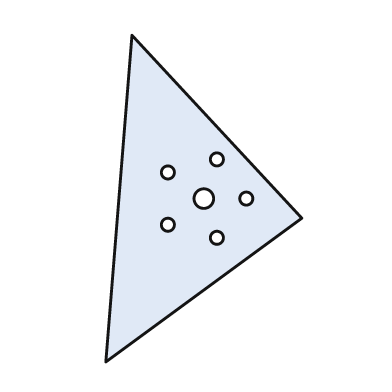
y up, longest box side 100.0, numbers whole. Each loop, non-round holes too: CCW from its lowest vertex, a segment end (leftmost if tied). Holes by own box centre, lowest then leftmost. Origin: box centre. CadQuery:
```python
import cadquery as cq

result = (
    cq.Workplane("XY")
    .moveTo(-30.0, -50.0)
    .lineTo(30.0, -6.0)
    .lineTo(-22.0, 50.0)
    .close()
    .moveTo(4.0, -12.0)
    .circle(2.0)
    .moveTo(-11.0, -8.0)
    .circle(2.0)
    .moveTo(0.0, 0.0)
    .circle(3.0)
    .moveTo(13.0, 0.0)
    .circle(2.0)
    .moveTo(-11.0, 8.0)
    .circle(2.0)
    .moveTo(4.0, 12.0)
    .circle(2.0)
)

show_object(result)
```